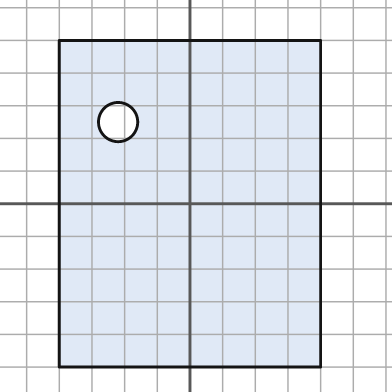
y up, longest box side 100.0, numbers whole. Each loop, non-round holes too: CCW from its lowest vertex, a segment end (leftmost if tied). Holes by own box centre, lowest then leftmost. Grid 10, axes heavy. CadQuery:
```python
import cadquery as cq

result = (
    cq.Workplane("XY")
    .moveTo(-40.0, -50.0)
    .lineTo(40.0, -50.0)
    .lineTo(40.0, 50.0)
    .lineTo(-40.0, 50.0)
    .close()
    .moveTo(-22.0, 25.0)
    .circle(6.0)
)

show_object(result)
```